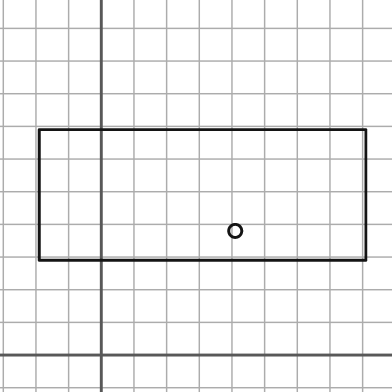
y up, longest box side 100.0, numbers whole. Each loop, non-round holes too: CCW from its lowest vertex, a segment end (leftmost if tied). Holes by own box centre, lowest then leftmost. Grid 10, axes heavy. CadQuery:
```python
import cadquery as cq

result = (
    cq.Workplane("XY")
    .moveTo(-19.0, 29.0)
    .lineTo(81.0, 29.0)
    .lineTo(81.0, 69.0)
    .lineTo(-19.0, 69.0)
    .close()
    .moveTo(41.0, 38.0)
    .circle(2.0)
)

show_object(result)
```